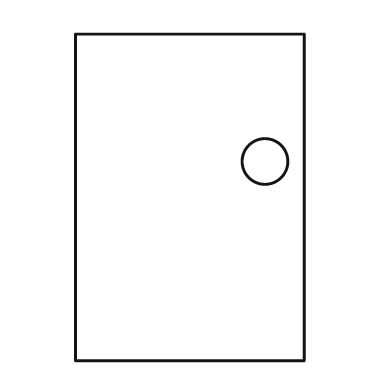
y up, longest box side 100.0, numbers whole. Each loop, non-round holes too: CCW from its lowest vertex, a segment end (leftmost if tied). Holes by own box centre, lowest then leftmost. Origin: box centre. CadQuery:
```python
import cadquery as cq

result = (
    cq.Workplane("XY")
    .moveTo(-35.0, -50.0)
    .lineTo(35.0, -50.0)
    .lineTo(35.0, 50.0)
    .lineTo(-35.0, 50.0)
    .close()
    .moveTo(23.0, 11.0)
    .circle(7.0)
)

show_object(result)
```